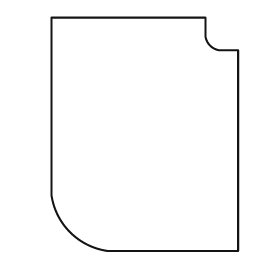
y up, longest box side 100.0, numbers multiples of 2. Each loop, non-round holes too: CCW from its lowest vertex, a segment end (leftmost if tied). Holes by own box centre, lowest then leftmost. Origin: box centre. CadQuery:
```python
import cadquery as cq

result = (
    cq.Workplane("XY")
    .moveTo(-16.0, -50.0)
    .lineTo(40.0, -50.0)
    .lineTo(40.0, 36.0)
    .lineTo(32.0, 36.0)
    .threePointArc((28.0, 38.0), (26.0, 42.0))
    .lineTo(26.0, 50.0)
    .lineTo(-40.0, 50.0)
    .lineTo(-40.0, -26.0)
    .threePointArc((-32.0, -42.0), (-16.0, -50.0))
    .close()
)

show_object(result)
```